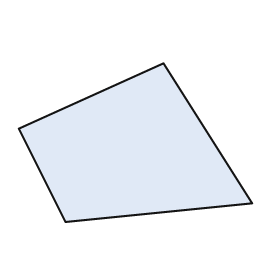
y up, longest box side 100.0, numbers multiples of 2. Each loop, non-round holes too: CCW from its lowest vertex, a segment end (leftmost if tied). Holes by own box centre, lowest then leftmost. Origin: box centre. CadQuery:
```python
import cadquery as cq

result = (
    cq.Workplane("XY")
    .moveTo(-30.0, -34.0)
    .lineTo(50.0, -26.0)
    .lineTo(12.0, 34.0)
    .lineTo(-50.0, 6.0)
    .close()
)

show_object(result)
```